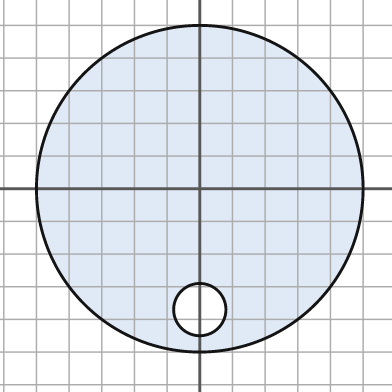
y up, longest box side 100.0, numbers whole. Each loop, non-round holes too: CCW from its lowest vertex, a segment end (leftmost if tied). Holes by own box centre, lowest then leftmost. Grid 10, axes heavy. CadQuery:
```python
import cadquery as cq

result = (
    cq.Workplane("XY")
    .moveTo(0.0, 0.0)
    .circle(50.0)
    .moveTo(0.0, -37.0)
    .circle(8.0)
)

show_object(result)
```